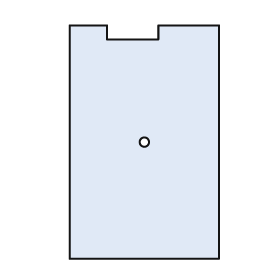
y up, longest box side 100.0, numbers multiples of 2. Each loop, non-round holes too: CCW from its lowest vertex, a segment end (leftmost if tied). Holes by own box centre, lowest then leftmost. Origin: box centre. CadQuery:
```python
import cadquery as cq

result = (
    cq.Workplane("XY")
    .moveTo(-32.0, -50.0)
    .lineTo(32.0, -50.0)
    .lineTo(32.0, 50.0)
    .lineTo(6.0, 50.0)
    .lineTo(6.0, 44.0)
    .lineTo(-16.0, 44.0)
    .lineTo(-16.0, 50.0)
    .lineTo(-32.0, 50.0)
    .close()
    .moveTo(0.0, 0.0)
    .circle(2.0)
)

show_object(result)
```